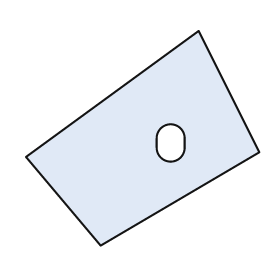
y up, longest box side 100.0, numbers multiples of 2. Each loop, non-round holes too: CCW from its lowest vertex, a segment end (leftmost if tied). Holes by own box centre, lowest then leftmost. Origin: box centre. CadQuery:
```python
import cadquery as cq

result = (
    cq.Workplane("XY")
    .moveTo(-18.0, -46.0)
    .lineTo(50.0, -6.0)
    .lineTo(24.0, 46.0)
    .lineTo(-50.0, -8.0)
    .close()
    .moveTo(6.0, -4.0)
    .threePointArc((12.0, -10.0), (18.0, -4.0))
    .lineTo(18.0, 0.0)
    .threePointArc((12.0, 6.0), (6.0, 0.0))
    .close()
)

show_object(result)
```